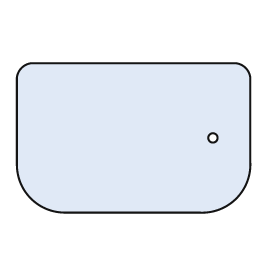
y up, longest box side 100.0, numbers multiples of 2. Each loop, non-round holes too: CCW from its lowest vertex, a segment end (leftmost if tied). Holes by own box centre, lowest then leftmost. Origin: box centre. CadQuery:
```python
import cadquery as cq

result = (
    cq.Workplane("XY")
    .moveTo(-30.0, -32.0)
    .lineTo(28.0, -32.0)
    .threePointArc((44.0, -26.0), (50.0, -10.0))
    .lineTo(50.0, 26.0)
    .threePointArc((48.0, 30.0), (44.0, 32.0))
    .lineTo(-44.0, 32.0)
    .threePointArc((-48.0, 30.0), (-50.0, 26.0))
    .lineTo(-50.0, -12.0)
    .threePointArc((-44.0, -26.0), (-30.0, -32.0))
    .close()
    .moveTo(34.0, 0.0)
    .circle(2.0)
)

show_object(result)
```